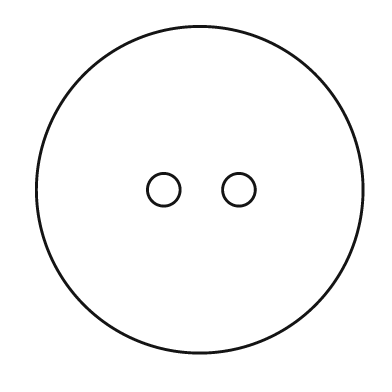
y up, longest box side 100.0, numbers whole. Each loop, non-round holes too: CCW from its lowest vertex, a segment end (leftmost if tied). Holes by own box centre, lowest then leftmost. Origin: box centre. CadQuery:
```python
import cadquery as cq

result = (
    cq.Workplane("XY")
    .moveTo(0.0, 0.0)
    .circle(50.0)
    .moveTo(-11.0, 0.0)
    .circle(5.0)
    .moveTo(12.0, 0.0)
    .circle(5.0)
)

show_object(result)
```